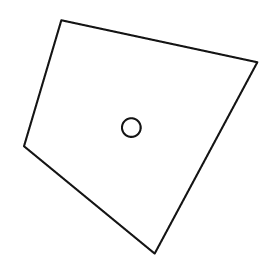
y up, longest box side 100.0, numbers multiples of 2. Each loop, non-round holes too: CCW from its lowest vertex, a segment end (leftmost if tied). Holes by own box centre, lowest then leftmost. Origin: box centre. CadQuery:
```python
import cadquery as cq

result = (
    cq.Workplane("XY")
    .moveTo(6.0, -50.0)
    .lineTo(50.0, 32.0)
    .lineTo(-34.0, 50.0)
    .lineTo(-50.0, -4.0)
    .close()
    .moveTo(-4.0, 4.0)
    .circle(4.0)
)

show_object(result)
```